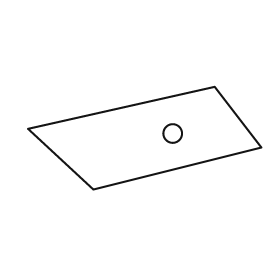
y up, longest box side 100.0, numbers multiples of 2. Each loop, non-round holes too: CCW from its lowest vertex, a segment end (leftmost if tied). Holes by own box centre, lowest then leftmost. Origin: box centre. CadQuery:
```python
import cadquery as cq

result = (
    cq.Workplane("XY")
    .moveTo(-22.0, -22.0)
    .lineTo(50.0, -4.0)
    .lineTo(30.0, 22.0)
    .lineTo(-50.0, 4.0)
    .close()
    .moveTo(12.0, 2.0)
    .circle(4.0)
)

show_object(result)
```